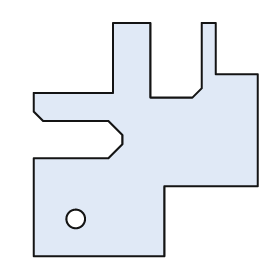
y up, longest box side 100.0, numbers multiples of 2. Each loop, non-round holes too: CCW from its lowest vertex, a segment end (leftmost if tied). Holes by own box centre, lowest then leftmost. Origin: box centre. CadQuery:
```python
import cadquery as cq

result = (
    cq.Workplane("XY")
    .moveTo(-48.0, -50.0)
    .lineTo(8.0, -50.0)
    .lineTo(8.0, -20.0)
    .lineTo(48.0, -20.0)
    .lineTo(48.0, 28.0)
    .lineTo(30.0, 28.0)
    .lineTo(30.0, 50.0)
    .lineTo(24.0, 50.0)
    .lineTo(24.0, 22.0)
    .lineTo(20.0, 18.0)
    .lineTo(2.0, 18.0)
    .lineTo(2.0, 50.0)
    .lineTo(-14.0, 50.0)
    .lineTo(-14.0, 20.0)
    .lineTo(-48.0, 20.0)
    .lineTo(-48.0, 12.0)
    .lineTo(-44.0, 8.0)
    .lineTo(-16.0, 8.0)
    .lineTo(-10.0, 2.0)
    .lineTo(-10.0, -2.0)
    .lineTo(-16.0, -8.0)
    .lineTo(-48.0, -8.0)
    .close()
    .moveTo(-30.0, -34.0)
    .circle(4.0)
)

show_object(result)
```